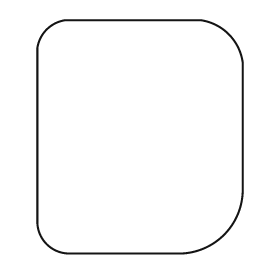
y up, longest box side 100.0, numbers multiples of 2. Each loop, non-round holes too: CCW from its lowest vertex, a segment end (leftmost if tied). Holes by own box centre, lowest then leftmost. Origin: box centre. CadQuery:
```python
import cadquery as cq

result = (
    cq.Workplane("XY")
    .moveTo(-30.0, -50.0)
    .lineTo(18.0, -50.0)
    .threePointArc((36.0, -42.0), (44.0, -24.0))
    .lineTo(44.0, 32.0)
    .threePointArc((38.0, 44.0), (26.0, 50.0))
    .lineTo(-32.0, 50.0)
    .threePointArc((-40.0, 46.0), (-44.0, 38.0))
    .lineTo(-44.0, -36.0)
    .threePointArc((-40.0, -46.0), (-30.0, -50.0))
    .close()
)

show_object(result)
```